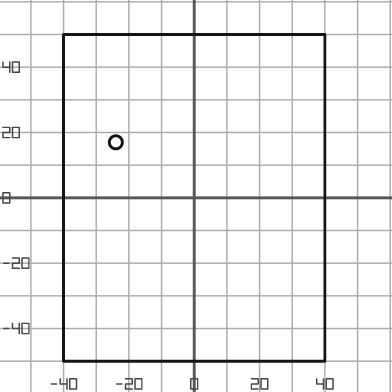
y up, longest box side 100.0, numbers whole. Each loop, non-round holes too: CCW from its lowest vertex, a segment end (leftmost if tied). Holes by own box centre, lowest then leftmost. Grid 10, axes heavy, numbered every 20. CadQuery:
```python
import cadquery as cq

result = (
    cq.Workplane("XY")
    .moveTo(-40.0, -50.0)
    .lineTo(40.0, -50.0)
    .lineTo(40.0, 50.0)
    .lineTo(-40.0, 50.0)
    .close()
    .moveTo(-24.0, 17.0)
    .circle(2.0)
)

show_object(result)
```